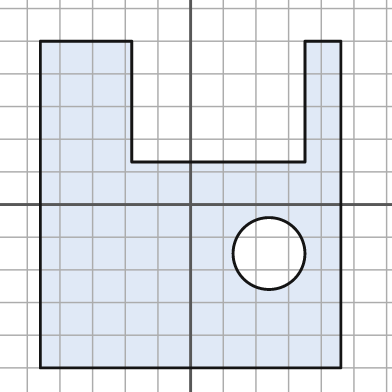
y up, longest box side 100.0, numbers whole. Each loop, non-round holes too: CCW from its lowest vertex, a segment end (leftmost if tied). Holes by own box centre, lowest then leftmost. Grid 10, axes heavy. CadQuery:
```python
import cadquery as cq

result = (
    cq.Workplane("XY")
    .moveTo(-46.0, -50.0)
    .lineTo(46.0, -50.0)
    .lineTo(46.0, 50.0)
    .lineTo(35.0, 50.0)
    .lineTo(35.0, 13.0)
    .lineTo(-18.0, 13.0)
    .lineTo(-18.0, 50.0)
    .lineTo(-46.0, 50.0)
    .close()
    .moveTo(24.0, -15.0)
    .circle(11.0)
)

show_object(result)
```